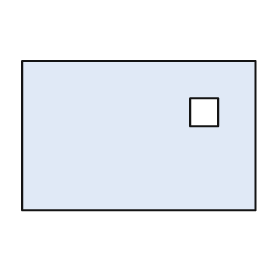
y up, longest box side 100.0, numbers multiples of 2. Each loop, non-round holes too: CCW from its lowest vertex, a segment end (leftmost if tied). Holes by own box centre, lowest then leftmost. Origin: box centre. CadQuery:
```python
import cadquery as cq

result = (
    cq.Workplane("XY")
    .moveTo(-50.0, -32.0)
    .lineTo(50.0, -32.0)
    .lineTo(50.0, 32.0)
    .lineTo(-50.0, 32.0)
    .close()
    .moveTo(22.0, 4.0)
    .lineTo(34.0, 4.0)
    .lineTo(34.0, 16.0)
    .lineTo(22.0, 16.0)
    .close()
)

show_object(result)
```